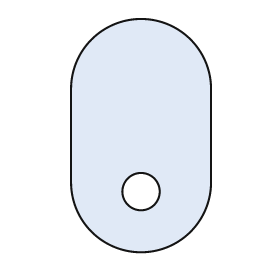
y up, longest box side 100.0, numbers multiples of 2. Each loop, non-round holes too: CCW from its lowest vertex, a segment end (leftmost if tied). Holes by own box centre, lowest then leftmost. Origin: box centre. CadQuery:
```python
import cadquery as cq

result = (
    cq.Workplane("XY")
    .moveTo(-30.0, -20.0)
    .threePointArc((0.0, -50.0), (30.0, -20.0))
    .lineTo(30.0, 20.0)
    .threePointArc((0.0, 50.0), (-30.0, 20.0))
    .close()
    .moveTo(0.0, -24.0)
    .circle(8.0)
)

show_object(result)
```